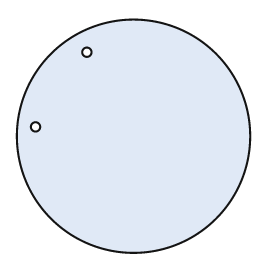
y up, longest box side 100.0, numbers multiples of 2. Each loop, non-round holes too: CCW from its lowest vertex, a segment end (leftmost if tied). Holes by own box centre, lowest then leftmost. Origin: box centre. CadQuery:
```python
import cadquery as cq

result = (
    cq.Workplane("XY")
    .moveTo(0.0, 0.0)
    .circle(50.0)
    .moveTo(-42.0, 4.0)
    .circle(2.0)
    .moveTo(-20.0, 36.0)
    .circle(2.0)
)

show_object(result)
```